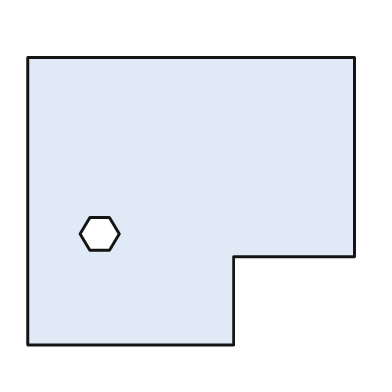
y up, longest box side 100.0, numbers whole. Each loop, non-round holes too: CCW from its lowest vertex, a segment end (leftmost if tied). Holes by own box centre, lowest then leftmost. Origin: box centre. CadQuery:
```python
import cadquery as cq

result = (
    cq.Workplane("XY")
    .moveTo(-50.0, -44.0)
    .lineTo(13.0, -44.0)
    .lineTo(13.0, -17.0)
    .lineTo(50.0, -17.0)
    .lineTo(50.0, 44.0)
    .lineTo(-50.0, 44.0)
    .close()
    .moveTo(-31.0, -15.0)
    .lineTo(-25.0, -15.0)
    .lineTo(-22.0, -10.0)
    .lineTo(-25.0, -5.0)
    .lineTo(-31.0, -5.0)
    .lineTo(-34.0, -10.0)
    .close()
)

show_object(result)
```